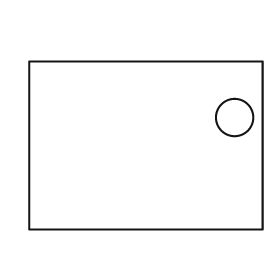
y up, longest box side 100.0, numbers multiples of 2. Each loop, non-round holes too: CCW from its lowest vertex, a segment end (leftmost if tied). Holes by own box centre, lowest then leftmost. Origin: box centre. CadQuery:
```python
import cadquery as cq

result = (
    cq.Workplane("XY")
    .moveTo(-50.0, -36.0)
    .lineTo(50.0, -36.0)
    .lineTo(50.0, 36.0)
    .lineTo(-50.0, 36.0)
    .close()
    .moveTo(38.0, 12.0)
    .circle(8.0)
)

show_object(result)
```